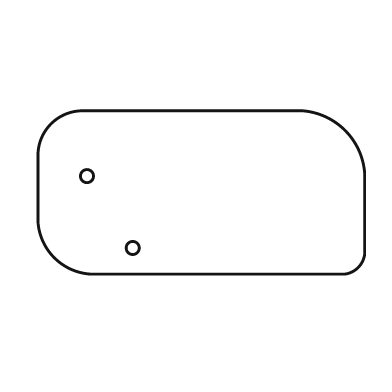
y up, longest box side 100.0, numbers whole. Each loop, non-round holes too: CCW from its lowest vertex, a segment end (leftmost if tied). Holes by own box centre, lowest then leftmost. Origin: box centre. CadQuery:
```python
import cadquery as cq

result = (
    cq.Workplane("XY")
    .moveTo(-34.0, -25.0)
    .lineTo(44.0, -25.0)
    .threePointArc((48.0, -23.0), (50.0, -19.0))
    .lineTo(50.0, 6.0)
    .threePointArc((44.0, 19.0), (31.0, 25.0))
    .lineTo(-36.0, 25.0)
    .threePointArc((-46.0, 21.0), (-50.0, 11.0))
    .lineTo(-50.0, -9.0)
    .threePointArc((-45.0, -20.0), (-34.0, -25.0))
    .close()
    .moveTo(-21.0, -17.0)
    .circle(2.0)
    .moveTo(-35.0, 5.0)
    .circle(2.0)
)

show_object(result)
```